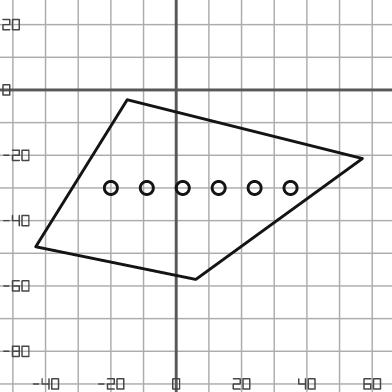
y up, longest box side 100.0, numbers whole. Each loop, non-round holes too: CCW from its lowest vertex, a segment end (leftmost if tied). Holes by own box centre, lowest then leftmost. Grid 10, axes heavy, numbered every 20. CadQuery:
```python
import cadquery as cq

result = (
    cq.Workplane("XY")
    .moveTo(6.0, -58.0)
    .lineTo(57.0, -21.0)
    .lineTo(-15.0, -3.0)
    .lineTo(-43.0, -48.0)
    .close()
    .moveTo(-20.0, -30.0)
    .circle(2.0)
    .moveTo(-9.0, -30.0)
    .circle(2.0)
    .moveTo(2.0, -30.0)
    .circle(2.0)
    .moveTo(13.0, -30.0)
    .circle(2.0)
    .moveTo(24.0, -30.0)
    .circle(2.0)
    .moveTo(35.0, -30.0)
    .circle(2.0)
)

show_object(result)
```